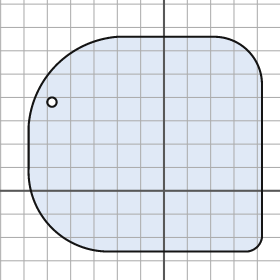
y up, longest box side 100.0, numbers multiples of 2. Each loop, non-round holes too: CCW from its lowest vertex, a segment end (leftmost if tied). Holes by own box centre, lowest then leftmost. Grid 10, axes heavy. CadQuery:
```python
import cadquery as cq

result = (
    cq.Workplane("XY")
    .moveTo(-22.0, -26.0)
    .lineTo(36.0, -26.0)
    .threePointArc((40.0, -24.0), (42.0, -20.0))
    .lineTo(42.0, 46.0)
    .threePointArc((36.0, 60.0), (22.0, 66.0))
    .lineTo(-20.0, 66.0)
    .threePointArc((-46.0, 54.0), (-58.0, 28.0))
    .lineTo(-58.0, 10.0)
    .threePointArc((-48.0, -16.0), (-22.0, -26.0))
    .close()
    .moveTo(-48.0, 38.0)
    .circle(2.0)
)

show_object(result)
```